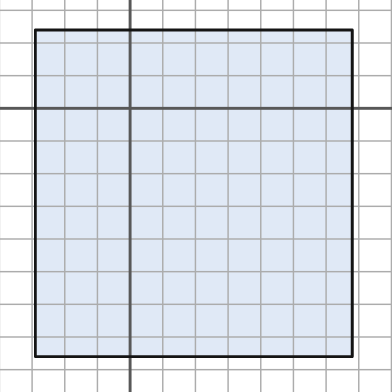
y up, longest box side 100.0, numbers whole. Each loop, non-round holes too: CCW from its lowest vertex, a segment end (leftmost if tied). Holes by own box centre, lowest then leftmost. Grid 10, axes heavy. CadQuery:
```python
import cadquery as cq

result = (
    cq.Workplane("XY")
    .moveTo(-29.0, -76.0)
    .lineTo(68.0, -76.0)
    .lineTo(68.0, 24.0)
    .lineTo(-29.0, 24.0)
    .close()
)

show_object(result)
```